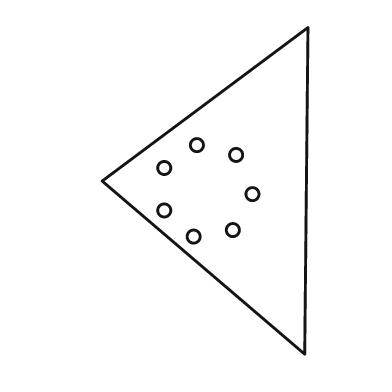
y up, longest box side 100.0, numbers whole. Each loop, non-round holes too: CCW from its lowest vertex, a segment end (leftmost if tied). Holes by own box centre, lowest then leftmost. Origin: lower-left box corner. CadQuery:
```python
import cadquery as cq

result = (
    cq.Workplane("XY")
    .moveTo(62.0, 0.0)
    .lineTo(63.0, 100.0)
    .lineTo(0.0, 53.0)
    .close()
    .moveTo(28.0, 36.0)
    .circle(2.0)
    .moveTo(40.0, 38.0)
    .circle(2.0)
    .moveTo(19.0, 44.0)
    .circle(2.0)
    .moveTo(46.0, 49.0)
    .circle(2.0)
    .moveTo(19.0, 57.0)
    .circle(2.0)
    .moveTo(41.0, 61.0)
    .circle(2.0)
    .moveTo(29.0, 64.0)
    .circle(2.0)
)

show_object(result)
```